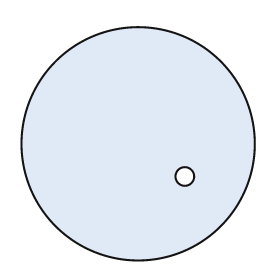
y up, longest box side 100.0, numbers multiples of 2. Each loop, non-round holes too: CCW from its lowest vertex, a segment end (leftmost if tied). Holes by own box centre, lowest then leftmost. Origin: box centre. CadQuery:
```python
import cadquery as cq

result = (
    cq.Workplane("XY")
    .moveTo(0.0, 0.0)
    .circle(50.0)
    .moveTo(20.0, -14.0)
    .circle(4.0)
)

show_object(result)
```